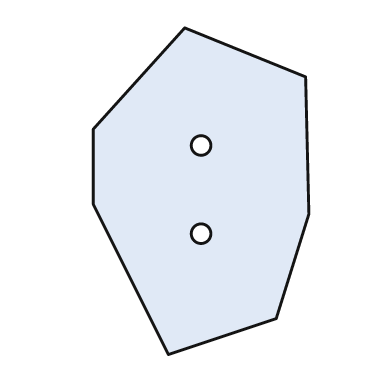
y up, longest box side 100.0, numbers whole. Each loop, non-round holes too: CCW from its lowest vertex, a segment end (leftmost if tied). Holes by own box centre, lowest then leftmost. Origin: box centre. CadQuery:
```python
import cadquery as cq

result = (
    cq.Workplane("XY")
    .moveTo(-10.0, -50.0)
    .lineTo(23.0, -39.0)
    .lineTo(33.0, -7.0)
    .lineTo(32.0, 35.0)
    .lineTo(-5.0, 50.0)
    .lineTo(-33.0, 19.0)
    .lineTo(-33.0, -4.0)
    .close()
    .moveTo(0.0, -13.0)
    .circle(3.0)
    .moveTo(0.0, 14.0)
    .circle(3.0)
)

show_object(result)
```